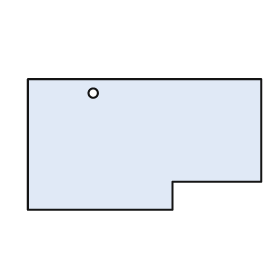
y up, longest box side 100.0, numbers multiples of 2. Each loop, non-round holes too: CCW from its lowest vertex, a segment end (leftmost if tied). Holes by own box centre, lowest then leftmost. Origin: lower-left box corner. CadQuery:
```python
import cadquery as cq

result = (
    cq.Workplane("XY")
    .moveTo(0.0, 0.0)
    .lineTo(62.0, 0.0)
    .lineTo(62.0, 12.0)
    .lineTo(100.0, 12.0)
    .lineTo(100.0, 56.0)
    .lineTo(0.0, 56.0)
    .close()
    .moveTo(28.0, 50.0)
    .circle(2.0)
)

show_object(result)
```